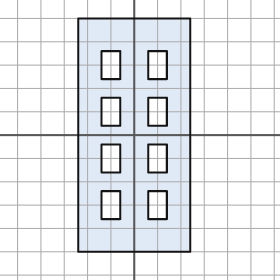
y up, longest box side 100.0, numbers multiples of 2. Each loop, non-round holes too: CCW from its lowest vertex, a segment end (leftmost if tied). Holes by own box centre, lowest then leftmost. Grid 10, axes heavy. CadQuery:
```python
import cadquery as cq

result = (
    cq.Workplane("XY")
    .moveTo(-24.0, -50.0)
    .lineTo(24.0, -50.0)
    .lineTo(24.0, 50.0)
    .lineTo(-24.0, 50.0)
    .close()
    .moveTo(-14.0, -36.0)
    .lineTo(-6.0, -36.0)
    .lineTo(-6.0, -24.0)
    .lineTo(-14.0, -24.0)
    .close()
    .moveTo(6.0, -36.0)
    .lineTo(14.0, -36.0)
    .lineTo(14.0, -24.0)
    .lineTo(6.0, -24.0)
    .close()
    .moveTo(-14.0, -16.0)
    .lineTo(-6.0, -16.0)
    .lineTo(-6.0, -4.0)
    .lineTo(-14.0, -4.0)
    .close()
    .moveTo(6.0, -16.0)
    .lineTo(14.0, -16.0)
    .lineTo(14.0, -4.0)
    .lineTo(6.0, -4.0)
    .close()
    .moveTo(-14.0, 4.0)
    .lineTo(-6.0, 4.0)
    .lineTo(-6.0, 16.0)
    .lineTo(-14.0, 16.0)
    .close()
    .moveTo(6.0, 4.0)
    .lineTo(14.0, 4.0)
    .lineTo(14.0, 16.0)
    .lineTo(6.0, 16.0)
    .close()
    .moveTo(-14.0, 24.0)
    .lineTo(-6.0, 24.0)
    .lineTo(-6.0, 36.0)
    .lineTo(-14.0, 36.0)
    .close()
    .moveTo(6.0, 24.0)
    .lineTo(14.0, 24.0)
    .lineTo(14.0, 36.0)
    .lineTo(6.0, 36.0)
    .close()
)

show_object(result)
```